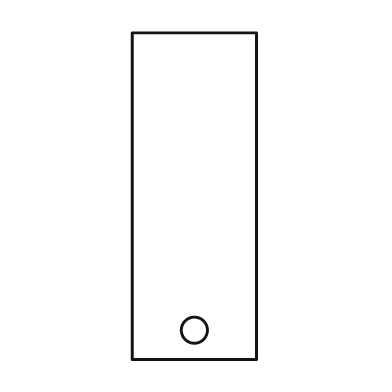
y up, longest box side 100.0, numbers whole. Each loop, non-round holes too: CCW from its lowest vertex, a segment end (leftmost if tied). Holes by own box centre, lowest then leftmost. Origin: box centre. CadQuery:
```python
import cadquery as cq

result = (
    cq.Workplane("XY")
    .moveTo(-19.0, -50.0)
    .lineTo(19.0, -50.0)
    .lineTo(19.0, 50.0)
    .lineTo(-19.0, 50.0)
    .close()
    .moveTo(0.0, -41.0)
    .circle(4.0)
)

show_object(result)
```